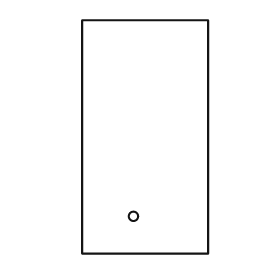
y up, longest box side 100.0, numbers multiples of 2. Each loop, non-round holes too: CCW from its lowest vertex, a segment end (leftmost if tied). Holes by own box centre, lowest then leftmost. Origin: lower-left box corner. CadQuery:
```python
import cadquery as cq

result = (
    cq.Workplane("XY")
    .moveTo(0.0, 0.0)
    .lineTo(54.0, 0.0)
    .lineTo(54.0, 100.0)
    .lineTo(0.0, 100.0)
    .close()
    .moveTo(22.0, 16.0)
    .circle(2.0)
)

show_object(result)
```